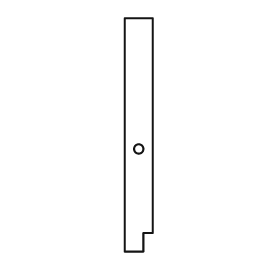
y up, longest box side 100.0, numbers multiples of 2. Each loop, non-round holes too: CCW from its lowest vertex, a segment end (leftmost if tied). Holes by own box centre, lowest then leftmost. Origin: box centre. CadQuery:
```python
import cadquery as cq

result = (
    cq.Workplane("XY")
    .moveTo(-6.0, -50.0)
    .lineTo(2.0, -50.0)
    .lineTo(2.0, -42.0)
    .lineTo(6.0, -42.0)
    .lineTo(6.0, 50.0)
    .lineTo(-6.0, 50.0)
    .close()
    .moveTo(0.0, -6.0)
    .circle(2.0)
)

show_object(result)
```